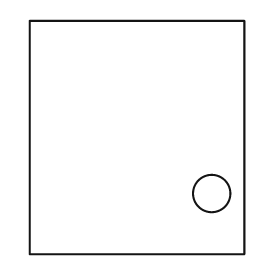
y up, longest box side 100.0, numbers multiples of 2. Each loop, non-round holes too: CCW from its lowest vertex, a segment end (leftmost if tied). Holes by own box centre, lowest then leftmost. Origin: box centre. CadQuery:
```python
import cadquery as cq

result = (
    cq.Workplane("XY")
    .moveTo(-46.0, -50.0)
    .lineTo(46.0, -50.0)
    .lineTo(46.0, 50.0)
    .lineTo(-46.0, 50.0)
    .close()
    .moveTo(32.0, -24.0)
    .circle(8.0)
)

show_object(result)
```